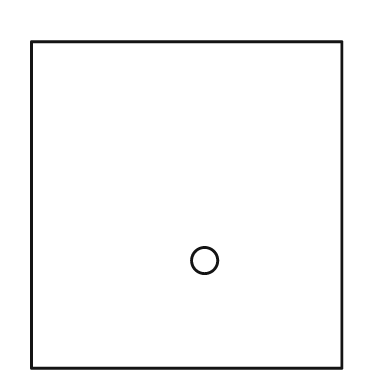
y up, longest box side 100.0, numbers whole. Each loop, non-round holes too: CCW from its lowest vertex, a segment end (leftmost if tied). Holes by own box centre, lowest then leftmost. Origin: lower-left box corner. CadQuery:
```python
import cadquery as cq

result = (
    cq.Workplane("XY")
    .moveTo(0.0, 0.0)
    .lineTo(95.0, 0.0)
    .lineTo(95.0, 100.0)
    .lineTo(0.0, 100.0)
    .close()
    .moveTo(53.0, 33.0)
    .circle(4.0)
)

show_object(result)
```